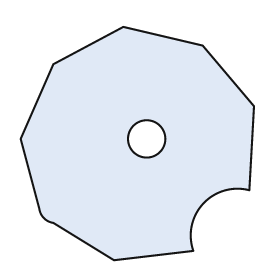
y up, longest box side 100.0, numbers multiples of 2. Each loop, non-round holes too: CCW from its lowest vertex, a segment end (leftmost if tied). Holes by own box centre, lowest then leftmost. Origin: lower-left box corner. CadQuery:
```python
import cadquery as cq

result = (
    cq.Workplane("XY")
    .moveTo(40.0, 0.0)
    .lineTo(74.0, 4.0)
    .threePointArc((78.0, 24.0), (98.0, 30.0))
    .lineTo(100.0, 66.0)
    .lineTo(78.0, 92.0)
    .lineTo(44.0, 100.0)
    .lineTo(14.0, 84.0)
    .lineTo(0.0, 52.0)
    .lineTo(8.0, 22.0)
    .threePointArc((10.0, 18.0), (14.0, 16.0))
    .close()
    .moveTo(54.0, 52.0)
    .circle(8.0)
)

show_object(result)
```